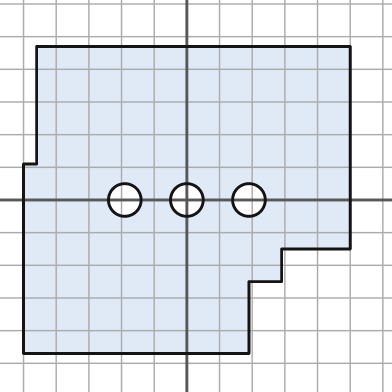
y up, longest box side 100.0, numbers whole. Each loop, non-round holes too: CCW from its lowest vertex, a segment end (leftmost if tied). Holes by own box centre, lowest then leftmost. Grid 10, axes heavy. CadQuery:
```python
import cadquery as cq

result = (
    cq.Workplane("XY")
    .moveTo(-50.0, -47.0)
    .lineTo(19.0, -47.0)
    .lineTo(19.0, -25.0)
    .lineTo(29.0, -25.0)
    .lineTo(29.0, -15.0)
    .lineTo(50.0, -15.0)
    .lineTo(50.0, 47.0)
    .lineTo(-46.0, 47.0)
    .lineTo(-46.0, 11.0)
    .lineTo(-50.0, 11.0)
    .close()
    .moveTo(-19.0, 0.0)
    .circle(5.0)
    .moveTo(0.0, 0.0)
    .circle(5.0)
    .moveTo(19.0, 0.0)
    .circle(5.0)
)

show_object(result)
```